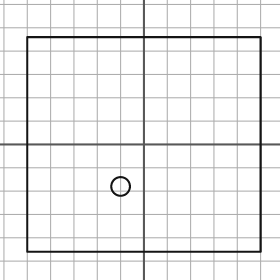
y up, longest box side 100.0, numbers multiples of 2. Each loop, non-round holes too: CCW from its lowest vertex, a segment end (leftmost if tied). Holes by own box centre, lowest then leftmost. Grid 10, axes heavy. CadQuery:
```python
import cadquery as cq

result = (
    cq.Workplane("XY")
    .moveTo(-50.0, -46.0)
    .lineTo(50.0, -46.0)
    .lineTo(50.0, 46.0)
    .lineTo(-50.0, 46.0)
    .close()
    .moveTo(-10.0, -18.0)
    .circle(4.0)
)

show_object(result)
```